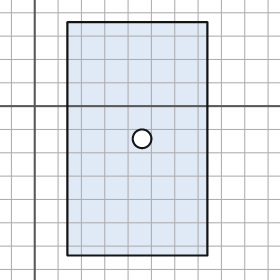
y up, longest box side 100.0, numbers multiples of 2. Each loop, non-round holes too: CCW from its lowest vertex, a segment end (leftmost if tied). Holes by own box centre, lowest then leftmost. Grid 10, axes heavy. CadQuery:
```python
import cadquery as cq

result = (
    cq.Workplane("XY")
    .moveTo(14.0, -64.0)
    .lineTo(74.0, -64.0)
    .lineTo(74.0, 36.0)
    .lineTo(14.0, 36.0)
    .close()
    .moveTo(46.0, -14.0)
    .circle(4.0)
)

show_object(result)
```